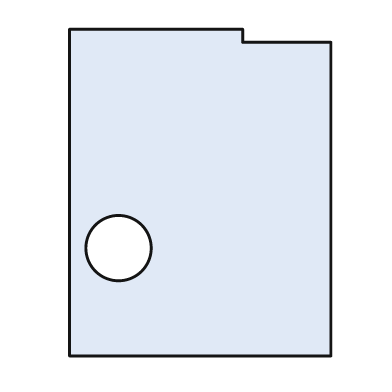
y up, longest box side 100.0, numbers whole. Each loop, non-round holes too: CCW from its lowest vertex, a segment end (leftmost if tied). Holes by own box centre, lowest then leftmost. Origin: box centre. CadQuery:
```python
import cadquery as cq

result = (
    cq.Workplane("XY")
    .moveTo(-40.0, -50.0)
    .lineTo(40.0, -50.0)
    .lineTo(40.0, 46.0)
    .lineTo(13.0, 46.0)
    .lineTo(13.0, 50.0)
    .lineTo(-40.0, 50.0)
    .close()
    .moveTo(-25.0, -17.0)
    .circle(10.0)
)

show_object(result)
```